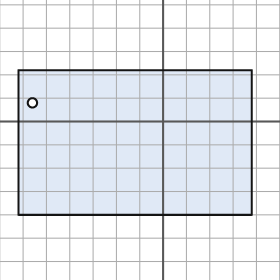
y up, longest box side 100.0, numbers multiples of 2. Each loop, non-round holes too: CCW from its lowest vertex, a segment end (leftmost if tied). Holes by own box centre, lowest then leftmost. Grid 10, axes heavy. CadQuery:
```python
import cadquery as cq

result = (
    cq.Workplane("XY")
    .moveTo(-62.0, -40.0)
    .lineTo(38.0, -40.0)
    .lineTo(38.0, 22.0)
    .lineTo(-62.0, 22.0)
    .close()
    .moveTo(-56.0, 8.0)
    .circle(2.0)
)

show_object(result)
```